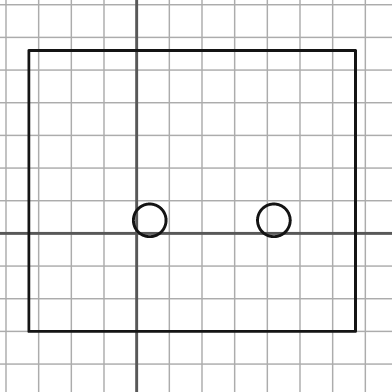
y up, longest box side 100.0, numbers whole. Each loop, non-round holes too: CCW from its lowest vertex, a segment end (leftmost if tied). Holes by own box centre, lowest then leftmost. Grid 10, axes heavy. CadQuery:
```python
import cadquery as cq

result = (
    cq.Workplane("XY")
    .moveTo(-33.0, -30.0)
    .lineTo(67.0, -30.0)
    .lineTo(67.0, 56.0)
    .lineTo(-33.0, 56.0)
    .close()
    .moveTo(4.0, 4.0)
    .circle(5.0)
    .moveTo(42.0, 4.0)
    .circle(5.0)
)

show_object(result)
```